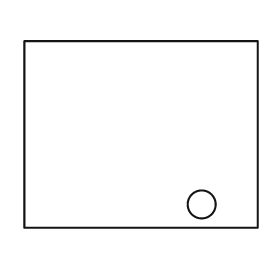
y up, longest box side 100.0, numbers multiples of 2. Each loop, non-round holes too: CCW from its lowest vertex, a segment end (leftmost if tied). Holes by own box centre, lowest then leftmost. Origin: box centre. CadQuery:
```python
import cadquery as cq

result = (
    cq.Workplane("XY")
    .moveTo(-50.0, -40.0)
    .lineTo(50.0, -40.0)
    .lineTo(50.0, 40.0)
    .lineTo(-50.0, 40.0)
    .close()
    .moveTo(26.0, -30.0)
    .circle(6.0)
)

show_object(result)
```